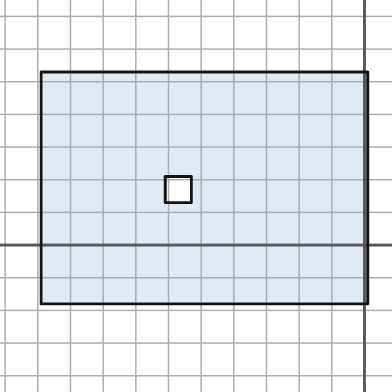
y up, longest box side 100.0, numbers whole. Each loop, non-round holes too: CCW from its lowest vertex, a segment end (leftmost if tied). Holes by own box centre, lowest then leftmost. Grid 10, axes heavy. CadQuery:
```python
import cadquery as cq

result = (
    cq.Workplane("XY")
    .moveTo(-99.0, -18.0)
    .lineTo(1.0, -18.0)
    .lineTo(1.0, 53.0)
    .lineTo(-99.0, 53.0)
    .close()
    .moveTo(-61.0, 13.0)
    .lineTo(-53.0, 13.0)
    .lineTo(-53.0, 21.0)
    .lineTo(-61.0, 21.0)
    .close()
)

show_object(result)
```